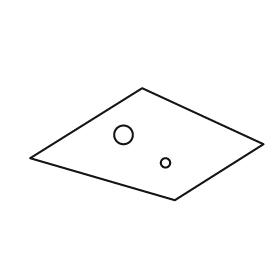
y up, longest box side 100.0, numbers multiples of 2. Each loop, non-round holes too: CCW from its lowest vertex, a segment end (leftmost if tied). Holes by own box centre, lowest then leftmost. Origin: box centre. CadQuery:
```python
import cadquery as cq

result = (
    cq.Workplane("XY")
    .moveTo(12.0, -24.0)
    .lineTo(50.0, 0.0)
    .lineTo(-2.0, 24.0)
    .lineTo(-50.0, -6.0)
    .close()
    .moveTo(8.0, -8.0)
    .circle(2.0)
    .moveTo(-10.0, 4.0)
    .circle(4.0)
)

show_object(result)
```